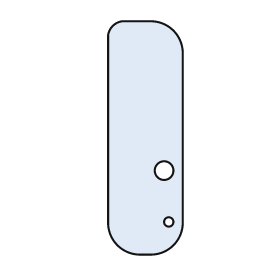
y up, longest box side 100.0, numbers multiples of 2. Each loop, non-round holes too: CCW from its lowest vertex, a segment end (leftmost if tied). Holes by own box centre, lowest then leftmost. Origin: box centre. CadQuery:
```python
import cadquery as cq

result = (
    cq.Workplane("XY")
    .moveTo(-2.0, -50.0)
    .lineTo(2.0, -50.0)
    .threePointArc((12.0, -46.0), (16.0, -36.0))
    .lineTo(16.0, 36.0)
    .threePointArc((12.0, 46.0), (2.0, 50.0))
    .lineTo(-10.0, 50.0)
    .threePointArc((-14.0, 48.0), (-16.0, 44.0))
    .lineTo(-16.0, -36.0)
    .threePointArc((-12.0, -46.0), (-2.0, -50.0))
    .close()
    .moveTo(10.0, -36.0)
    .circle(2.0)
    .moveTo(8.0, -14.0)
    .circle(4.0)
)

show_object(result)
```